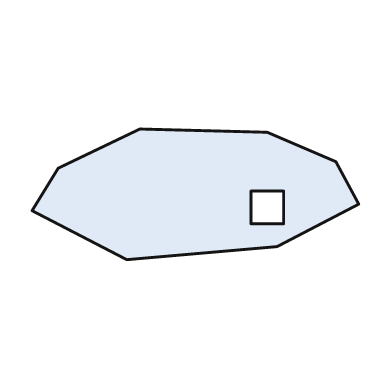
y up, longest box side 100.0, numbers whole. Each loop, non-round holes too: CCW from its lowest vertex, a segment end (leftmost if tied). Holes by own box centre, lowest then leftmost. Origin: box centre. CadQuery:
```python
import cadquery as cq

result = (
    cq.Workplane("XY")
    .moveTo(-21.0, -20.0)
    .lineTo(25.0, -16.0)
    .lineTo(50.0, -3.0)
    .lineTo(43.0, 10.0)
    .lineTo(22.0, 19.0)
    .lineTo(-17.0, 20.0)
    .lineTo(-42.0, 8.0)
    .lineTo(-50.0, -5.0)
    .close()
    .moveTo(17.0, -9.0)
    .lineTo(27.0, -9.0)
    .lineTo(27.0, 1.0)
    .lineTo(17.0, 1.0)
    .close()
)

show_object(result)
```